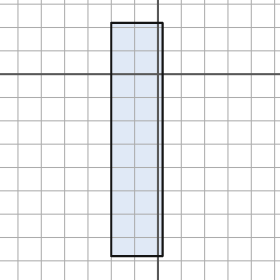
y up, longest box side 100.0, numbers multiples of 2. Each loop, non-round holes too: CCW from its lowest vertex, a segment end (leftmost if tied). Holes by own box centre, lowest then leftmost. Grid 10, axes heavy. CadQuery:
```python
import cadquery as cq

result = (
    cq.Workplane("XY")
    .moveTo(-20.0, -78.0)
    .lineTo(2.0, -78.0)
    .lineTo(2.0, 22.0)
    .lineTo(-20.0, 22.0)
    .close()
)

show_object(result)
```